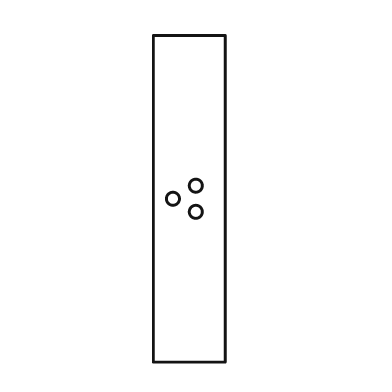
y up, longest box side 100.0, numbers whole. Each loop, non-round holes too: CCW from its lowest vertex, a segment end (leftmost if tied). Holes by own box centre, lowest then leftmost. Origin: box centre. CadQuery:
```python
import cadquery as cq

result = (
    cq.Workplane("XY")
    .moveTo(-11.0, -50.0)
    .lineTo(11.0, -50.0)
    .lineTo(11.0, 50.0)
    .lineTo(-11.0, 50.0)
    .close()
    .moveTo(2.0, -4.0)
    .circle(2.0)
    .moveTo(-5.0, 0.0)
    .circle(2.0)
    .moveTo(2.0, 4.0)
    .circle(2.0)
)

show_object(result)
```